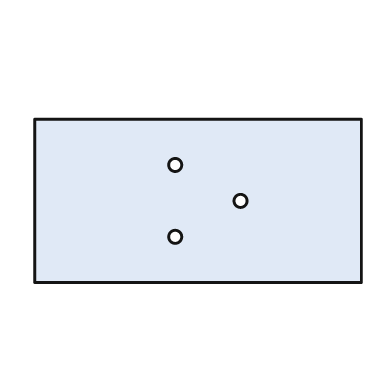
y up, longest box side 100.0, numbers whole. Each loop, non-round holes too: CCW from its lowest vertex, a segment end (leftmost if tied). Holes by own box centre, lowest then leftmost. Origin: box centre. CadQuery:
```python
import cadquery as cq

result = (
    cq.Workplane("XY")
    .moveTo(-50.0, -25.0)
    .lineTo(50.0, -25.0)
    .lineTo(50.0, 25.0)
    .lineTo(-50.0, 25.0)
    .close()
    .moveTo(-7.0, -11.0)
    .circle(2.0)
    .moveTo(13.0, 0.0)
    .circle(2.0)
    .moveTo(-7.0, 11.0)
    .circle(2.0)
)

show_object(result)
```